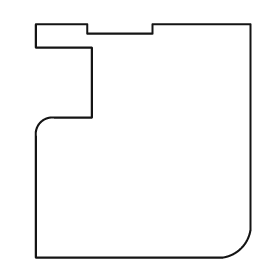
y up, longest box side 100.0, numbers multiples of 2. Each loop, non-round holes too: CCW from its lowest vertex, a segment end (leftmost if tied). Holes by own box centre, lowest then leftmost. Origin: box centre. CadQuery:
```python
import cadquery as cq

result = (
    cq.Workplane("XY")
    .moveTo(-46.0, -50.0)
    .lineTo(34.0, -50.0)
    .threePointArc((42.0, -46.0), (46.0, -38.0))
    .lineTo(46.0, 50.0)
    .lineTo(4.0, 50.0)
    .lineTo(4.0, 46.0)
    .lineTo(-24.0, 46.0)
    .lineTo(-24.0, 50.0)
    .lineTo(-46.0, 50.0)
    .lineTo(-46.0, 40.0)
    .lineTo(-22.0, 40.0)
    .lineTo(-22.0, 10.0)
    .lineTo(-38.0, 10.0)
    .threePointArc((-44.0, 8.0), (-46.0, 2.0))
    .close()
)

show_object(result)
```